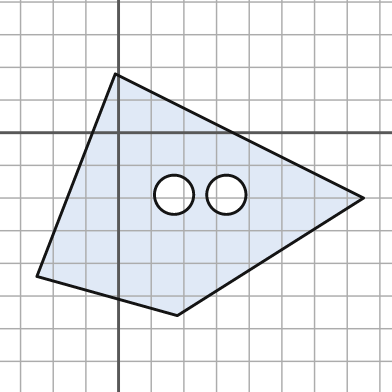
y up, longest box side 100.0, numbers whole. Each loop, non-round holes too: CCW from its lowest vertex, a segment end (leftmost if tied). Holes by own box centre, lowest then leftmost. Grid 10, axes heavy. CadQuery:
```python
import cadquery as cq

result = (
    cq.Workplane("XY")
    .moveTo(18.0, -56.0)
    .lineTo(75.0, -20.0)
    .lineTo(-1.0, 18.0)
    .lineTo(-25.0, -44.0)
    .close()
    .moveTo(17.0, -19.0)
    .circle(6.0)
    .moveTo(33.0, -19.0)
    .circle(6.0)
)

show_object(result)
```